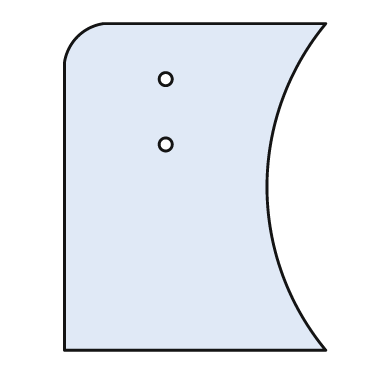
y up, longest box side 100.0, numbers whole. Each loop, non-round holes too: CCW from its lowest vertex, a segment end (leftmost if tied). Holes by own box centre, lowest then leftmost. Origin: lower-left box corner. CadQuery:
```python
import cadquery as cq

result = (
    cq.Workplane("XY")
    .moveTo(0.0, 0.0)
    .lineTo(80.0, 0.0)
    .threePointArc((62.0, 50.0), (80.0, 100.0))
    .lineTo(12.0, 100.0)
    .threePointArc((4.0, 96.0), (0.0, 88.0))
    .close()
    .moveTo(31.0, 63.0)
    .circle(2.0)
    .moveTo(31.0, 83.0)
    .circle(2.0)
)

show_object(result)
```